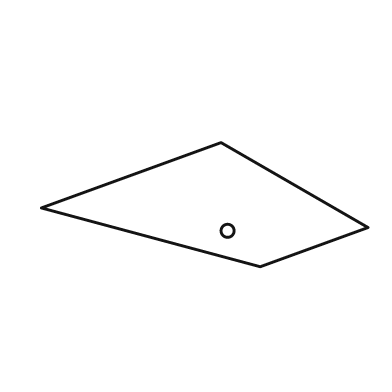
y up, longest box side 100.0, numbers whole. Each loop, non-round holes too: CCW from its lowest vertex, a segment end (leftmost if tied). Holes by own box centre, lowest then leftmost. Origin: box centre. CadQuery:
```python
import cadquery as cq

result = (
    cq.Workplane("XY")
    .moveTo(17.0, -19.0)
    .lineTo(50.0, -7.0)
    .lineTo(5.0, 19.0)
    .lineTo(-50.0, -1.0)
    .close()
    .moveTo(7.0, -8.0)
    .circle(2.0)
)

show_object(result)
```